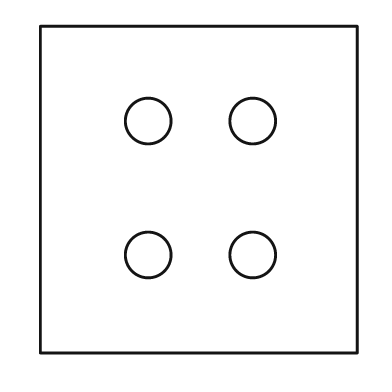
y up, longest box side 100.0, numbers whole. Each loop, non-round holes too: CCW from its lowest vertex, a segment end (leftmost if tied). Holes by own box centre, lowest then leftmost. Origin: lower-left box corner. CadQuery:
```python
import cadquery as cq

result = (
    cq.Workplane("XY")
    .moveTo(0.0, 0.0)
    .lineTo(97.0, 0.0)
    .lineTo(97.0, 100.0)
    .lineTo(0.0, 100.0)
    .close()
    .moveTo(33.0, 30.0)
    .circle(7.0)
    .moveTo(65.0, 30.0)
    .circle(7.0)
    .moveTo(33.0, 71.0)
    .circle(7.0)
    .moveTo(65.0, 71.0)
    .circle(7.0)
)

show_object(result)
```